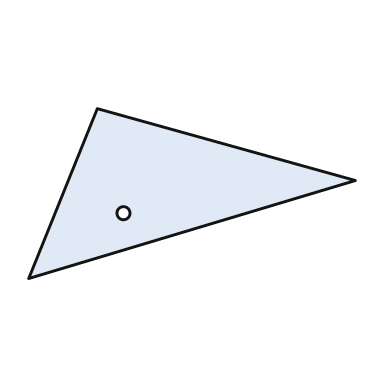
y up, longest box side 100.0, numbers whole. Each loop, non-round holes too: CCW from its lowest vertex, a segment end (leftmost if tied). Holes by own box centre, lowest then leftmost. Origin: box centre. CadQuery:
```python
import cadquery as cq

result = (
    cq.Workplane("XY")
    .moveTo(-50.0, -26.0)
    .lineTo(50.0, 4.0)
    .lineTo(-29.0, 26.0)
    .close()
    .moveTo(-21.0, -6.0)
    .circle(2.0)
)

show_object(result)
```